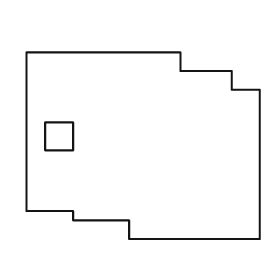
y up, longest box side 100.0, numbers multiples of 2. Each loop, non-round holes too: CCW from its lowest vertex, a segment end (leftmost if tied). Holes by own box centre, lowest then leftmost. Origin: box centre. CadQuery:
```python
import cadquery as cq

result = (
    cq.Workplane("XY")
    .moveTo(-6.0, -40.0)
    .lineTo(50.0, -40.0)
    .lineTo(50.0, 24.0)
    .lineTo(38.0, 24.0)
    .lineTo(38.0, 32.0)
    .lineTo(16.0, 32.0)
    .lineTo(16.0, 40.0)
    .lineTo(-50.0, 40.0)
    .lineTo(-50.0, -28.0)
    .lineTo(-30.0, -28.0)
    .lineTo(-30.0, -32.0)
    .lineTo(-6.0, -32.0)
    .close()
    .moveTo(-42.0, -2.0)
    .lineTo(-30.0, -2.0)
    .lineTo(-30.0, 10.0)
    .lineTo(-42.0, 10.0)
    .close()
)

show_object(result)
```